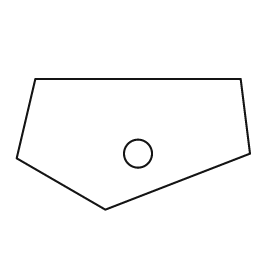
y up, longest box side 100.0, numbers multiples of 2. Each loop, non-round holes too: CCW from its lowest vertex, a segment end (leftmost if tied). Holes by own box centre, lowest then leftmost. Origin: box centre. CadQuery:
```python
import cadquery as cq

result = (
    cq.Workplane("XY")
    .moveTo(-12.0, -28.0)
    .lineTo(50.0, -4.0)
    .lineTo(46.0, 28.0)
    .lineTo(-42.0, 28.0)
    .lineTo(-50.0, -6.0)
    .close()
    .moveTo(2.0, -4.0)
    .circle(6.0)
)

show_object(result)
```